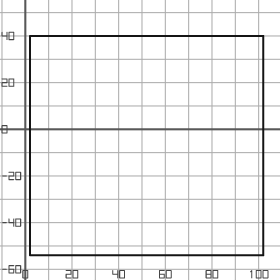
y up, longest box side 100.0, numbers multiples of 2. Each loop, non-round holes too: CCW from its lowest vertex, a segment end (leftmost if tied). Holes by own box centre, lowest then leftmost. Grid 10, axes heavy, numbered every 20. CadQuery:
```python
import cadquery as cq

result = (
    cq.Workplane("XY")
    .moveTo(2.0, -54.0)
    .lineTo(102.0, -54.0)
    .lineTo(102.0, 40.0)
    .lineTo(2.0, 40.0)
    .close()
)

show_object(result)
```